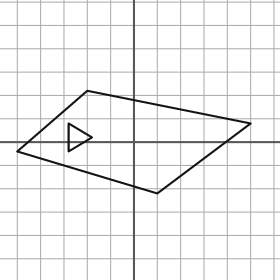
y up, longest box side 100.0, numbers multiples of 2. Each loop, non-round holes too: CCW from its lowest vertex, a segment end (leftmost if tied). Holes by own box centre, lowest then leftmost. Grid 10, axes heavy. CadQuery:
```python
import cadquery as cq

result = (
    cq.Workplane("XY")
    .moveTo(10.0, -22.0)
    .lineTo(50.0, 8.0)
    .lineTo(-20.0, 22.0)
    .lineTo(-50.0, -4.0)
    .close()
    .moveTo(-28.0, -4.0)
    .lineTo(-18.0, 2.0)
    .lineTo(-28.0, 8.0)
    .close()
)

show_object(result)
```